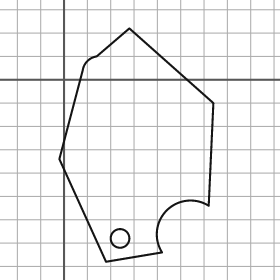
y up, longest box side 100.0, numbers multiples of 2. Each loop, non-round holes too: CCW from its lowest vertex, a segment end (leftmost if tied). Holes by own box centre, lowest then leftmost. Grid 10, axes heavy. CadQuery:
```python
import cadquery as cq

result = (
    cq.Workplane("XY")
    .moveTo(18.0, -78.0)
    .lineTo(42.0, -74.0)
    .threePointArc((44.0, -56.0), (62.0, -54.0))
    .lineTo(64.0, -10.0)
    .lineTo(28.0, 22.0)
    .lineTo(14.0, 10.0)
    .threePointArc((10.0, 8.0), (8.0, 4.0))
    .lineTo(-2.0, -34.0)
    .close()
    .moveTo(24.0, -68.0)
    .circle(4.0)
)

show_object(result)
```